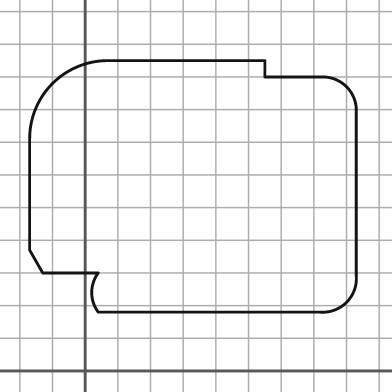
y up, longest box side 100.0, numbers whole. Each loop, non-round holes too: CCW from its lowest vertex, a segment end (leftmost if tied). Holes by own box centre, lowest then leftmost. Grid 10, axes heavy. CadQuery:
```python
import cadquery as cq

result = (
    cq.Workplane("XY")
    .moveTo(4.0, 18.0)
    .lineTo(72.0, 18.0)
    .threePointArc((80.0, 21.0), (83.0, 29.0))
    .lineTo(83.0, 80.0)
    .threePointArc((80.0, 87.0), (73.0, 90.0))
    .lineTo(55.0, 90.0)
    .lineTo(55.0, 95.0)
    .lineTo(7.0, 95.0)
    .threePointArc((-10.0, 88.0), (-17.0, 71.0))
    .lineTo(-17.0, 37.0)
    .lineTo(-13.0, 30.0)
    .lineTo(4.0, 30.0)
    .threePointArc((2.0, 24.0), (4.0, 18.0))
    .close()
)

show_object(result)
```